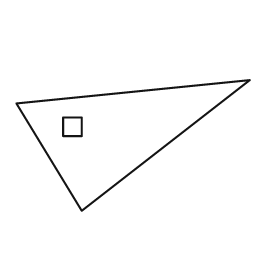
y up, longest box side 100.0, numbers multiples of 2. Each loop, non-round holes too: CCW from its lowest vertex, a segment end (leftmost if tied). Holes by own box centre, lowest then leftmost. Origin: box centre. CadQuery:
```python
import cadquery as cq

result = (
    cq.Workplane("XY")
    .moveTo(-22.0, -28.0)
    .lineTo(50.0, 28.0)
    .lineTo(-50.0, 18.0)
    .close()
    .moveTo(-30.0, 4.0)
    .lineTo(-22.0, 4.0)
    .lineTo(-22.0, 12.0)
    .lineTo(-30.0, 12.0)
    .close()
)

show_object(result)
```